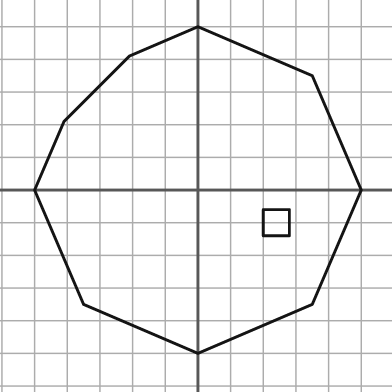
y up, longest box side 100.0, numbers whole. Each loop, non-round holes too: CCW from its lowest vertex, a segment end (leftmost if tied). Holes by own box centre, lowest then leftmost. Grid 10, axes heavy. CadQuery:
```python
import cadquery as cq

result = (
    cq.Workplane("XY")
    .moveTo(0.0, -50.0)
    .lineTo(35.0, -35.0)
    .lineTo(50.0, 0.0)
    .lineTo(35.0, 35.0)
    .lineTo(0.0, 50.0)
    .lineTo(-21.0, 41.0)
    .lineTo(-41.0, 21.0)
    .lineTo(-50.0, 0.0)
    .lineTo(-35.0, -35.0)
    .close()
    .moveTo(20.0, -14.0)
    .lineTo(28.0, -14.0)
    .lineTo(28.0, -6.0)
    .lineTo(20.0, -6.0)
    .close()
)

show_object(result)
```